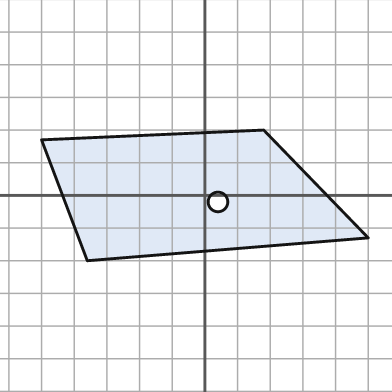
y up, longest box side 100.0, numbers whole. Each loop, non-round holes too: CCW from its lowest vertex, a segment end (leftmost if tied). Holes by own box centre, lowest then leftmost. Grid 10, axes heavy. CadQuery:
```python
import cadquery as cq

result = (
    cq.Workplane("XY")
    .moveTo(-36.0, -20.0)
    .lineTo(50.0, -13.0)
    .lineTo(18.0, 20.0)
    .lineTo(-50.0, 17.0)
    .close()
    .moveTo(4.0, -2.0)
    .circle(3.0)
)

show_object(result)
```